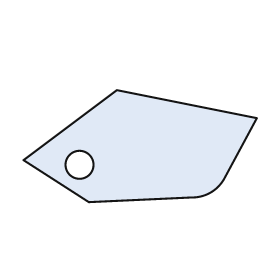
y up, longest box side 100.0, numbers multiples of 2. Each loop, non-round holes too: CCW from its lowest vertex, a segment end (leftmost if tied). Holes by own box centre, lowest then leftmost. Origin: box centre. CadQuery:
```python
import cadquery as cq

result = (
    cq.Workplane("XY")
    .moveTo(-22.0, -24.0)
    .lineTo(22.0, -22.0)
    .threePointArc((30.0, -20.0), (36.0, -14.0))
    .lineTo(50.0, 12.0)
    .lineTo(-10.0, 24.0)
    .lineTo(-50.0, -6.0)
    .close()
    .moveTo(-26.0, -8.0)
    .circle(6.0)
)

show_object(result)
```